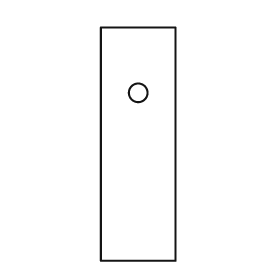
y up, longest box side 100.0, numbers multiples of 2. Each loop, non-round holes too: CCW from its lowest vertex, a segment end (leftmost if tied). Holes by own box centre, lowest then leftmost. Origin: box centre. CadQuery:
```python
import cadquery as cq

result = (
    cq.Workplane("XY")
    .moveTo(-16.0, -50.0)
    .lineTo(16.0, -50.0)
    .lineTo(16.0, 50.0)
    .lineTo(-16.0, 50.0)
    .close()
    .moveTo(0.0, 22.0)
    .circle(4.0)
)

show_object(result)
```